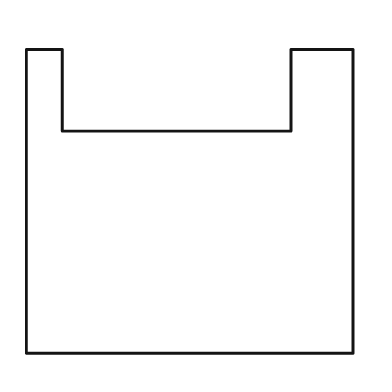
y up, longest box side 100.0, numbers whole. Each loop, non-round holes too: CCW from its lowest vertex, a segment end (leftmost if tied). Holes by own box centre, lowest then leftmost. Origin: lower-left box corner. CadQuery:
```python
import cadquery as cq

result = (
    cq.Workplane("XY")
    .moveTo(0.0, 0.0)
    .lineTo(100.0, 0.0)
    .lineTo(100.0, 93.0)
    .lineTo(81.0, 93.0)
    .lineTo(81.0, 68.0)
    .lineTo(11.0, 68.0)
    .lineTo(11.0, 93.0)
    .lineTo(0.0, 93.0)
    .close()
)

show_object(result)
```